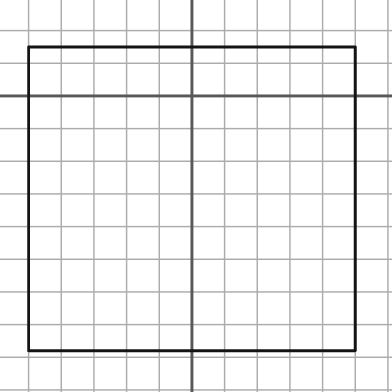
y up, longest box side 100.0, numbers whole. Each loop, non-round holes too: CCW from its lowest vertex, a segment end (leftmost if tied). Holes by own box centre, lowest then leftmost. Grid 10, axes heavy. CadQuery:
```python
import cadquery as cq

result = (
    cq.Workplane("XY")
    .moveTo(-50.0, -78.0)
    .lineTo(50.0, -78.0)
    .lineTo(50.0, 15.0)
    .lineTo(-50.0, 15.0)
    .close()
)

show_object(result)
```